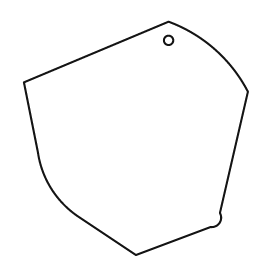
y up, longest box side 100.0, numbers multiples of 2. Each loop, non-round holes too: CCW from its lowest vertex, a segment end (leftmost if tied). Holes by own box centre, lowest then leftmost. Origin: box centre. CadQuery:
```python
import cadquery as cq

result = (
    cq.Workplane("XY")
    .moveTo(0.0, -50.0)
    .lineTo(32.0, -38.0)
    .threePointArc((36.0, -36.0), (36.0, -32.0))
    .lineTo(48.0, 20.0)
    .threePointArc((34.0, 38.0), (14.0, 50.0))
    .lineTo(-48.0, 24.0)
    .lineTo(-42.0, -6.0)
    .threePointArc((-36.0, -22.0), (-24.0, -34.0))
    .close()
    .moveTo(14.0, 42.0)
    .circle(2.0)
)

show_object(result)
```